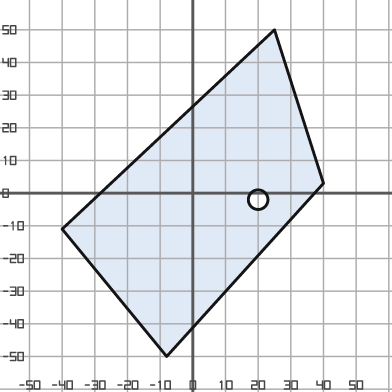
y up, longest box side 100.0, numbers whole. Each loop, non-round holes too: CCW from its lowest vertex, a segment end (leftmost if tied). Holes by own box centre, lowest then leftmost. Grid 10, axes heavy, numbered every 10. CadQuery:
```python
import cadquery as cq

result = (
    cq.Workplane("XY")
    .moveTo(-8.0, -50.0)
    .lineTo(40.0, 3.0)
    .lineTo(25.0, 50.0)
    .lineTo(-40.0, -11.0)
    .close()
    .moveTo(20.0, -2.0)
    .circle(3.0)
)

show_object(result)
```